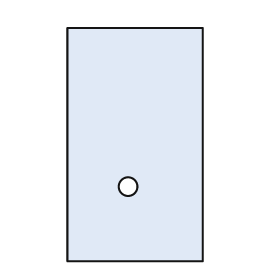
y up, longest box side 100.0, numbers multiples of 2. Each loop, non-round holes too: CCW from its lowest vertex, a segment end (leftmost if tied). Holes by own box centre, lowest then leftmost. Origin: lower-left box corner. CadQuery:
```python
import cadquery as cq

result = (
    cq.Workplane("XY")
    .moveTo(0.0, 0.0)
    .lineTo(58.0, 0.0)
    .lineTo(58.0, 100.0)
    .lineTo(0.0, 100.0)
    .close()
    .moveTo(26.0, 32.0)
    .circle(4.0)
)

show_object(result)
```